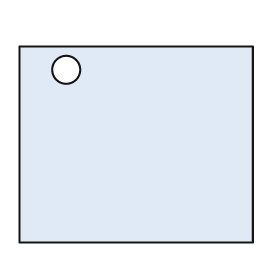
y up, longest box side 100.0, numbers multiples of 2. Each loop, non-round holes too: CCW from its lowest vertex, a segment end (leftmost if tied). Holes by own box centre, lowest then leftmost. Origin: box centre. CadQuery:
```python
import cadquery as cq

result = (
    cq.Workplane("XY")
    .moveTo(-50.0, -42.0)
    .lineTo(50.0, -42.0)
    .lineTo(50.0, 42.0)
    .lineTo(-50.0, 42.0)
    .close()
    .moveTo(-30.0, 32.0)
    .circle(6.0)
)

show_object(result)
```